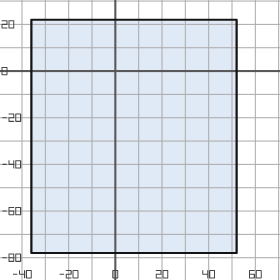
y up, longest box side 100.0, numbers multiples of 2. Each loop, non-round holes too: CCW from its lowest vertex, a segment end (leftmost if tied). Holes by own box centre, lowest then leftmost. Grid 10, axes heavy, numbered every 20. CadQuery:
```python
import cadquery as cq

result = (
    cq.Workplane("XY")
    .moveTo(-36.0, -78.0)
    .lineTo(52.0, -78.0)
    .lineTo(52.0, 22.0)
    .lineTo(-36.0, 22.0)
    .close()
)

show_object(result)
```